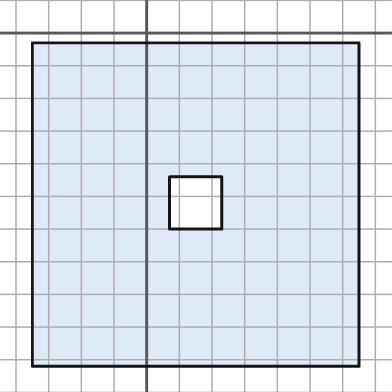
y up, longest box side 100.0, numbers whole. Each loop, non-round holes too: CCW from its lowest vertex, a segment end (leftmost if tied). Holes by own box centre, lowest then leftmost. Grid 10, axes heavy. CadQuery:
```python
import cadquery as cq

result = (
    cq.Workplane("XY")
    .moveTo(-35.0, -102.0)
    .lineTo(65.0, -102.0)
    .lineTo(65.0, -3.0)
    .lineTo(-35.0, -3.0)
    .close()
    .moveTo(7.0, -60.0)
    .lineTo(23.0, -60.0)
    .lineTo(23.0, -44.0)
    .lineTo(7.0, -44.0)
    .close()
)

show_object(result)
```